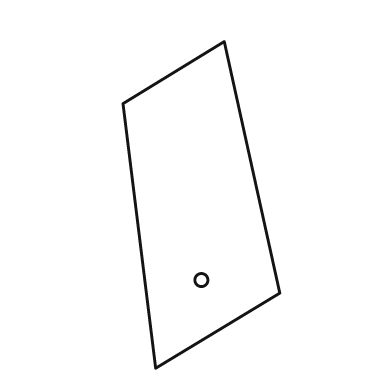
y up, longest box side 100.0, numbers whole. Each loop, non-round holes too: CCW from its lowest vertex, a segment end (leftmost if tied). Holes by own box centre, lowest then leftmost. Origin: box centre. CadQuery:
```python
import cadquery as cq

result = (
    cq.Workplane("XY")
    .moveTo(-14.0, -50.0)
    .lineTo(24.0, -27.0)
    .lineTo(7.0, 50.0)
    .lineTo(-24.0, 31.0)
    .close()
    .moveTo(0.0, -23.0)
    .circle(2.0)
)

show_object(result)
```